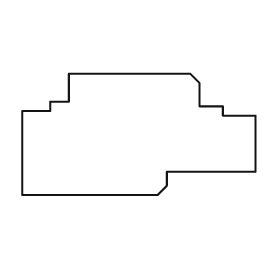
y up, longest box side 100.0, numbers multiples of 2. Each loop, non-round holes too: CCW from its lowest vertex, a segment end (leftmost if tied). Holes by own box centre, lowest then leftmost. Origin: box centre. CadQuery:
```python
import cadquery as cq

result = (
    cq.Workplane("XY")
    .moveTo(-50.0, -26.0)
    .lineTo(8.0, -26.0)
    .lineTo(12.0, -22.0)
    .lineTo(12.0, -16.0)
    .lineTo(50.0, -16.0)
    .lineTo(50.0, 8.0)
    .lineTo(36.0, 8.0)
    .lineTo(36.0, 12.0)
    .lineTo(26.0, 12.0)
    .lineTo(26.0, 22.0)
    .lineTo(22.0, 26.0)
    .lineTo(-30.0, 26.0)
    .lineTo(-30.0, 14.0)
    .lineTo(-38.0, 14.0)
    .lineTo(-38.0, 10.0)
    .lineTo(-50.0, 10.0)
    .close()
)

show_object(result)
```